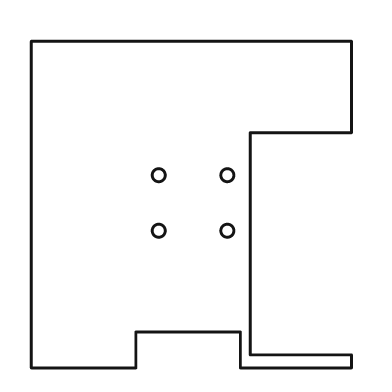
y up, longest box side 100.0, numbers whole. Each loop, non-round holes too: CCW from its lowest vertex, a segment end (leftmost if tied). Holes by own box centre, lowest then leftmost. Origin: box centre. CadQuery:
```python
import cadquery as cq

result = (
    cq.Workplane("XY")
    .moveTo(-49.0, -50.0)
    .lineTo(-17.0, -50.0)
    .lineTo(-17.0, -39.0)
    .lineTo(15.0, -39.0)
    .lineTo(15.0, -50.0)
    .lineTo(49.0, -50.0)
    .lineTo(49.0, -46.0)
    .lineTo(18.0, -46.0)
    .lineTo(18.0, 22.0)
    .lineTo(49.0, 22.0)
    .lineTo(49.0, 50.0)
    .lineTo(-49.0, 50.0)
    .close()
    .moveTo(-10.0, -8.0)
    .circle(2.0)
    .moveTo(11.0, -8.0)
    .circle(2.0)
    .moveTo(-10.0, 9.0)
    .circle(2.0)
    .moveTo(11.0, 9.0)
    .circle(2.0)
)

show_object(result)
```